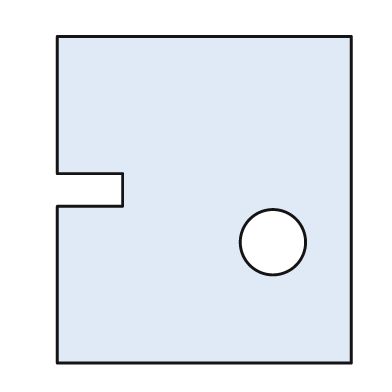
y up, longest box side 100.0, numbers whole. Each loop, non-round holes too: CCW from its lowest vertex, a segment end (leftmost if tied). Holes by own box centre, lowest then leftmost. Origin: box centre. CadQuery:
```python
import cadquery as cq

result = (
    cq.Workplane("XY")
    .moveTo(-45.0, -50.0)
    .lineTo(45.0, -50.0)
    .lineTo(45.0, 50.0)
    .lineTo(-45.0, 50.0)
    .lineTo(-45.0, 8.0)
    .lineTo(-25.0, 8.0)
    .lineTo(-25.0, -2.0)
    .lineTo(-45.0, -2.0)
    .close()
    .moveTo(21.0, -13.0)
    .circle(10.0)
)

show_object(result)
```